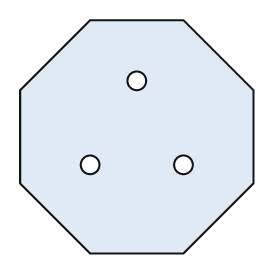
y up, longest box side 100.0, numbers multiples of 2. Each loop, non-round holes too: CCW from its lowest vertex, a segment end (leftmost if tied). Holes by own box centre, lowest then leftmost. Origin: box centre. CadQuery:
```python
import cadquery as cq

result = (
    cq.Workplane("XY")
    .moveTo(-20.0, -50.0)
    .lineTo(20.0, -50.0)
    .lineTo(50.0, -20.0)
    .lineTo(50.0, 20.0)
    .lineTo(20.0, 50.0)
    .lineTo(-20.0, 50.0)
    .lineTo(-50.0, 20.0)
    .lineTo(-50.0, -20.0)
    .close()
    .moveTo(-20.0, -12.0)
    .circle(4.0)
    .moveTo(20.0, -12.0)
    .circle(4.0)
    .moveTo(0.0, 24.0)
    .circle(4.0)
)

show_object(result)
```